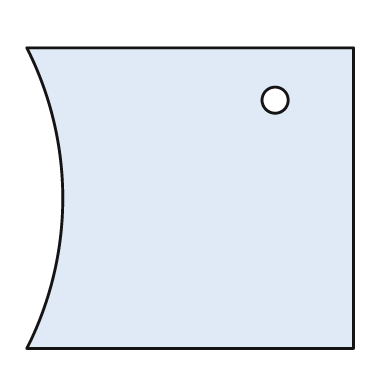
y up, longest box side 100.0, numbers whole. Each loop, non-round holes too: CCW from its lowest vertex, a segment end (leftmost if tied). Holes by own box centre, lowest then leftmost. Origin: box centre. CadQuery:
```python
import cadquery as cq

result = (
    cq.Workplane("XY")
    .moveTo(-50.0, -46.0)
    .lineTo(50.0, -46.0)
    .lineTo(50.0, 46.0)
    .lineTo(-50.0, 46.0)
    .threePointArc((-39.0, 0.0), (-50.0, -46.0))
    .close()
    .moveTo(26.0, 30.0)
    .circle(4.0)
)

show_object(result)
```